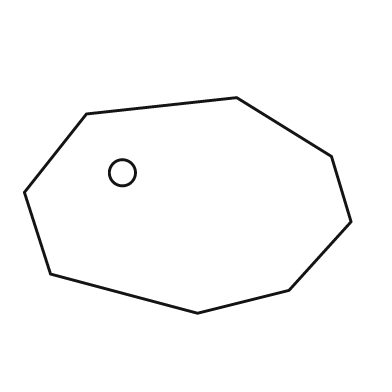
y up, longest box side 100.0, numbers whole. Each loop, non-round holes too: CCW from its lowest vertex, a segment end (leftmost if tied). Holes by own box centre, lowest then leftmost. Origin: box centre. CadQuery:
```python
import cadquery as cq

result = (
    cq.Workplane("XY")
    .moveTo(3.0, -33.0)
    .lineTo(31.0, -26.0)
    .lineTo(50.0, -5.0)
    .lineTo(44.0, 15.0)
    .lineTo(15.0, 33.0)
    .lineTo(-31.0, 28.0)
    .lineTo(-50.0, 4.0)
    .lineTo(-42.0, -21.0)
    .close()
    .moveTo(-20.0, 10.0)
    .circle(4.0)
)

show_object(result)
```